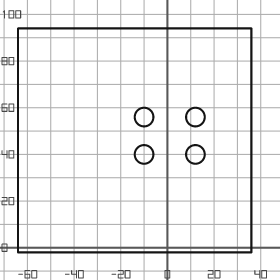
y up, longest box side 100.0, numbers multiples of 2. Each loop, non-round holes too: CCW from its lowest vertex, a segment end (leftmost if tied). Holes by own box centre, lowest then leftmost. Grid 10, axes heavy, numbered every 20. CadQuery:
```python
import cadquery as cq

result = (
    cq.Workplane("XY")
    .moveTo(-64.0, -2.0)
    .lineTo(36.0, -2.0)
    .lineTo(36.0, 94.0)
    .lineTo(-64.0, 94.0)
    .close()
    .moveTo(-10.0, 40.0)
    .circle(4.0)
    .moveTo(12.0, 40.0)
    .circle(4.0)
    .moveTo(-10.0, 56.0)
    .circle(4.0)
    .moveTo(12.0, 56.0)
    .circle(4.0)
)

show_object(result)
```